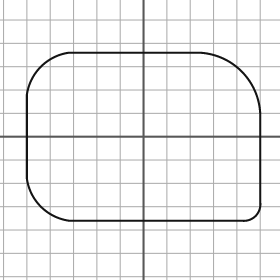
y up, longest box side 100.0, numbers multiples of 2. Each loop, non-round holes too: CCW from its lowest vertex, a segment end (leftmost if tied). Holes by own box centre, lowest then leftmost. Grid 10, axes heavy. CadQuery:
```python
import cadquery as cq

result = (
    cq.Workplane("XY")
    .moveTo(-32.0, -36.0)
    .lineTo(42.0, -36.0)
    .threePointArc((48.0, -34.0), (50.0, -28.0))
    .lineTo(50.0, 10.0)
    .threePointArc((42.0, 28.0), (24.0, 36.0))
    .lineTo(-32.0, 36.0)
    .threePointArc((-44.0, 30.0), (-50.0, 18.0))
    .lineTo(-50.0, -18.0)
    .threePointArc((-44.0, -30.0), (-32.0, -36.0))
    .close()
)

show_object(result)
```